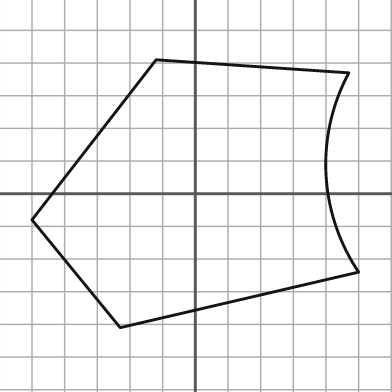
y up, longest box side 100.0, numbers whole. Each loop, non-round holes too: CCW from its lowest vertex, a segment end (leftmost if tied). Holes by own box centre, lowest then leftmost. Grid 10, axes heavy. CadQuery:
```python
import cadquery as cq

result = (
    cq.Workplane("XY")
    .moveTo(-23.0, -41.0)
    .lineTo(50.0, -24.0)
    .threePointArc((40.0, 6.0), (47.0, 37.0))
    .lineTo(-12.0, 41.0)
    .lineTo(-50.0, -8.0)
    .close()
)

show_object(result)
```